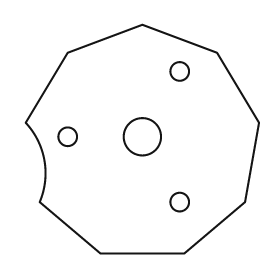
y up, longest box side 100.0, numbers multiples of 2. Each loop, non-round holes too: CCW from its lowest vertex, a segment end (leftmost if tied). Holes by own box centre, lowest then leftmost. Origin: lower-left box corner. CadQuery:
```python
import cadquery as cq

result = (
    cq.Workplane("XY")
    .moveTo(32.0, 0.0)
    .lineTo(68.0, 0.0)
    .lineTo(94.0, 22.0)
    .lineTo(100.0, 56.0)
    .lineTo(82.0, 86.0)
    .lineTo(50.0, 98.0)
    .lineTo(18.0, 86.0)
    .lineTo(0.0, 56.0)
    .threePointArc((8.0, 40.0), (6.0, 22.0))
    .close()
    .moveTo(66.0, 22.0)
    .circle(4.0)
    .moveTo(18.0, 50.0)
    .circle(4.0)
    .moveTo(50.0, 50.0)
    .circle(8.0)
    .moveTo(66.0, 78.0)
    .circle(4.0)
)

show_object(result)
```